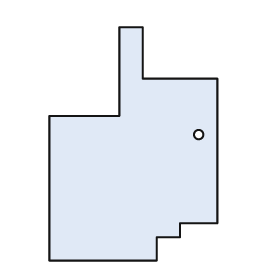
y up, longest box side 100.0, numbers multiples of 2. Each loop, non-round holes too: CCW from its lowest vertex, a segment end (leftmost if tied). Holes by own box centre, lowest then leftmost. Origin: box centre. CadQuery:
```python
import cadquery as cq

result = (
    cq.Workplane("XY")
    .moveTo(-36.0, -50.0)
    .lineTo(10.0, -50.0)
    .lineTo(10.0, -40.0)
    .lineTo(20.0, -40.0)
    .lineTo(20.0, -34.0)
    .lineTo(36.0, -34.0)
    .lineTo(36.0, 28.0)
    .lineTo(4.0, 28.0)
    .lineTo(4.0, 50.0)
    .lineTo(-6.0, 50.0)
    .lineTo(-6.0, 12.0)
    .lineTo(-36.0, 12.0)
    .close()
    .moveTo(28.0, 4.0)
    .circle(2.0)
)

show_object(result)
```